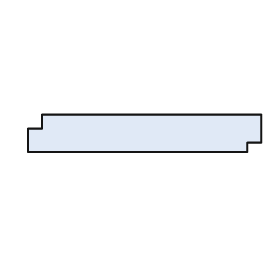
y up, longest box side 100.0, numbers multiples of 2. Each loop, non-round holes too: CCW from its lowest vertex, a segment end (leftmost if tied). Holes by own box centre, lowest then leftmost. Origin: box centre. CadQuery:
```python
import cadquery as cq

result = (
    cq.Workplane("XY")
    .moveTo(-50.0, -8.0)
    .lineTo(44.0, -8.0)
    .lineTo(44.0, -4.0)
    .lineTo(50.0, -4.0)
    .lineTo(50.0, 8.0)
    .lineTo(-44.0, 8.0)
    .lineTo(-44.0, 2.0)
    .lineTo(-50.0, 2.0)
    .close()
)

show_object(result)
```